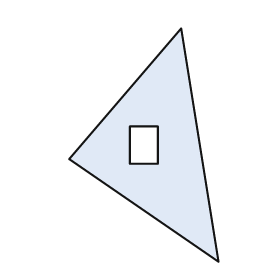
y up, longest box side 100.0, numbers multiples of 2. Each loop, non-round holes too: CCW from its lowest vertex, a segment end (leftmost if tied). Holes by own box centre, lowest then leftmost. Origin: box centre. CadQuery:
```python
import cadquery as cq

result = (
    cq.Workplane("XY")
    .moveTo(32.0, -50.0)
    .lineTo(16.0, 50.0)
    .lineTo(-32.0, -6.0)
    .close()
    .moveTo(-6.0, -8.0)
    .lineTo(6.0, -8.0)
    .lineTo(6.0, 8.0)
    .lineTo(-6.0, 8.0)
    .close()
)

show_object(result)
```